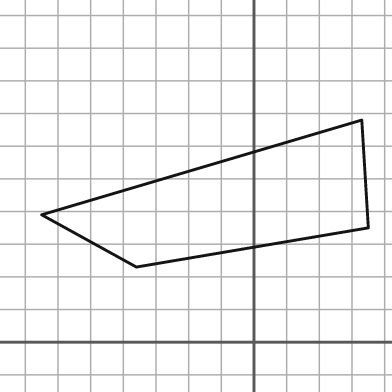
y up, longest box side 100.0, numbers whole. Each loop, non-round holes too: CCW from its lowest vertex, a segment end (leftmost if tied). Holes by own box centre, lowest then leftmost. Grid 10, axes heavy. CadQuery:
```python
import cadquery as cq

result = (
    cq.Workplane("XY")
    .moveTo(-36.0, 23.0)
    .lineTo(35.0, 35.0)
    .lineTo(33.0, 68.0)
    .lineTo(-65.0, 39.0)
    .close()
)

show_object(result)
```